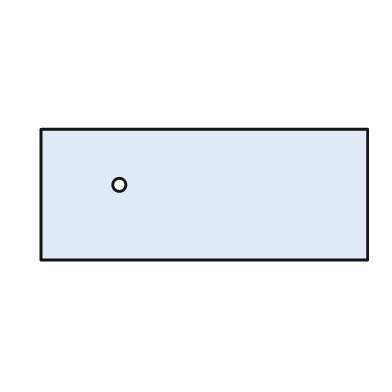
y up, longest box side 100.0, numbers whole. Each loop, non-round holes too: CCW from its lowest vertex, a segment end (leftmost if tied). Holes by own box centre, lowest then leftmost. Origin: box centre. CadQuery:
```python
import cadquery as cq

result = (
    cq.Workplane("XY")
    .moveTo(-50.0, -20.0)
    .lineTo(50.0, -20.0)
    .lineTo(50.0, 20.0)
    .lineTo(-50.0, 20.0)
    .close()
    .moveTo(-26.0, 3.0)
    .circle(2.0)
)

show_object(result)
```